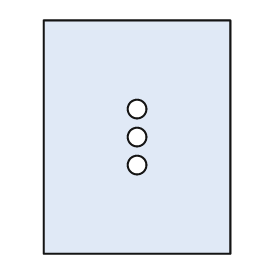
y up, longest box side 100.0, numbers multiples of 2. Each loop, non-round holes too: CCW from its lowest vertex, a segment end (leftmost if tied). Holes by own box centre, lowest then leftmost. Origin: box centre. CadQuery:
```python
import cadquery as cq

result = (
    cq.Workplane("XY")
    .moveTo(-40.0, -50.0)
    .lineTo(40.0, -50.0)
    .lineTo(40.0, 50.0)
    .lineTo(-40.0, 50.0)
    .close()
    .moveTo(0.0, -12.0)
    .circle(4.0)
    .moveTo(0.0, 0.0)
    .circle(4.0)
    .moveTo(0.0, 12.0)
    .circle(4.0)
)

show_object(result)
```